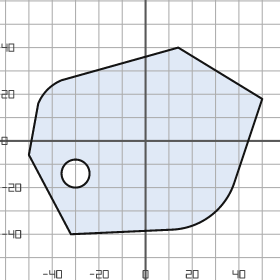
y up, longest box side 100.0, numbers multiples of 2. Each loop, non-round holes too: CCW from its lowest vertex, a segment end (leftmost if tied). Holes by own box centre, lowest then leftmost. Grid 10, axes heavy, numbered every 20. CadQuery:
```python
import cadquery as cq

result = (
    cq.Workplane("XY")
    .moveTo(-32.0, -40.0)
    .lineTo(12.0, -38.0)
    .threePointArc((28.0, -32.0), (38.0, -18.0))
    .lineTo(50.0, 18.0)
    .lineTo(14.0, 40.0)
    .lineTo(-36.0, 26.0)
    .threePointArc((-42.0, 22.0), (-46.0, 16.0))
    .lineTo(-50.0, -6.0)
    .close()
    .moveTo(-30.0, -14.0)
    .circle(6.0)
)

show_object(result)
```